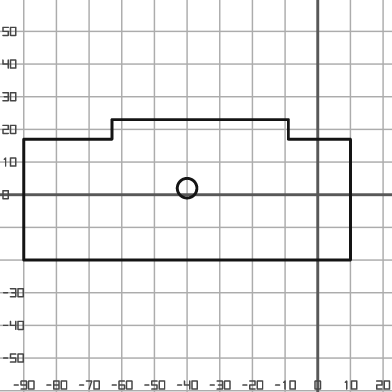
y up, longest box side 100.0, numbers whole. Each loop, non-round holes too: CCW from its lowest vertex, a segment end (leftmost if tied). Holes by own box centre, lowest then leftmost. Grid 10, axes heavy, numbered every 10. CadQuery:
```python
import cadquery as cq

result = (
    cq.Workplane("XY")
    .moveTo(-90.0, -20.0)
    .lineTo(10.0, -20.0)
    .lineTo(10.0, 17.0)
    .lineTo(-9.0, 17.0)
    .lineTo(-9.0, 23.0)
    .lineTo(-63.0, 23.0)
    .lineTo(-63.0, 17.0)
    .lineTo(-90.0, 17.0)
    .close()
    .moveTo(-40.0, 2.0)
    .circle(3.0)
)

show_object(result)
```